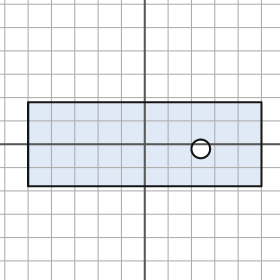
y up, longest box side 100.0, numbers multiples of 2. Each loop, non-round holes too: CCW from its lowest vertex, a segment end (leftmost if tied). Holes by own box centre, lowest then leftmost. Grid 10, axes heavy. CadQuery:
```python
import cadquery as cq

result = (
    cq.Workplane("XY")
    .moveTo(-50.0, -18.0)
    .lineTo(50.0, -18.0)
    .lineTo(50.0, 18.0)
    .lineTo(-50.0, 18.0)
    .close()
    .moveTo(24.0, -2.0)
    .circle(4.0)
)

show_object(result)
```